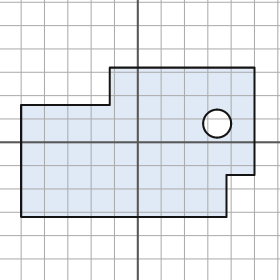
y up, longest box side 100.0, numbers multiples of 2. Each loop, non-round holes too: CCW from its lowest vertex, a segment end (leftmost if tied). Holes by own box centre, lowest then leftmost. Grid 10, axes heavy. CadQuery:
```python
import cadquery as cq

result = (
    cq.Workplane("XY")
    .moveTo(-50.0, -32.0)
    .lineTo(38.0, -32.0)
    .lineTo(38.0, -14.0)
    .lineTo(50.0, -14.0)
    .lineTo(50.0, 32.0)
    .lineTo(-12.0, 32.0)
    .lineTo(-12.0, 16.0)
    .lineTo(-50.0, 16.0)
    .close()
    .moveTo(34.0, 8.0)
    .circle(6.0)
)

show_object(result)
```